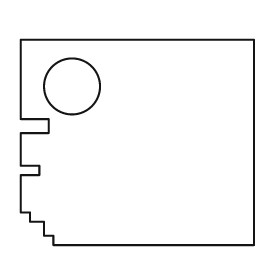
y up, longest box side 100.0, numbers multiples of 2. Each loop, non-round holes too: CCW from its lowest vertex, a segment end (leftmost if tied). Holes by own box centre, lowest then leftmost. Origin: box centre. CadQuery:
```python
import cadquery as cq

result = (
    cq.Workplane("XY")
    .moveTo(-36.0, -44.0)
    .lineTo(50.0, -44.0)
    .lineTo(50.0, 44.0)
    .lineTo(-50.0, 44.0)
    .lineTo(-50.0, 10.0)
    .lineTo(-38.0, 10.0)
    .lineTo(-38.0, 4.0)
    .lineTo(-50.0, 4.0)
    .lineTo(-50.0, -10.0)
    .lineTo(-42.0, -10.0)
    .lineTo(-42.0, -14.0)
    .lineTo(-50.0, -14.0)
    .lineTo(-50.0, -30.0)
    .lineTo(-46.0, -30.0)
    .lineTo(-46.0, -34.0)
    .lineTo(-40.0, -34.0)
    .lineTo(-40.0, -40.0)
    .lineTo(-36.0, -40.0)
    .close()
    .moveTo(-28.0, 24.0)
    .circle(12.0)
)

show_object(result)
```